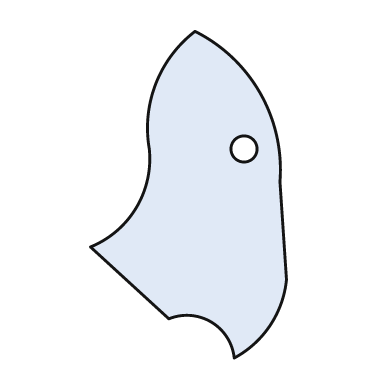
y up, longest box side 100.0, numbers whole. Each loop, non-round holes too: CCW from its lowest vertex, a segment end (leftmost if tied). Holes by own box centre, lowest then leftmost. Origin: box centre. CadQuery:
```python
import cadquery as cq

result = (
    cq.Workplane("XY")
    .moveTo(14.0, -50.0)
    .threePointArc((25.0, -40.0), (30.0, -26.0))
    .lineTo(28.0, 4.0)
    .threePointArc((22.0, 31.0), (2.0, 50.0))
    .threePointArc((-10.0, 34.0), (-12.0, 14.0))
    .threePointArc((-16.0, -4.0), (-30.0, -16.0))
    .lineTo(-6.0, -38.0)
    .threePointArc((7.0, -39.0), (14.0, -50.0))
    .close()
    .moveTo(17.0, 14.0)
    .circle(4.0)
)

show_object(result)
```